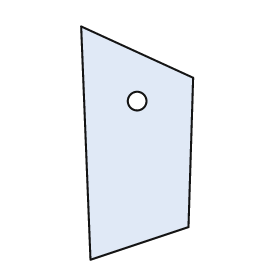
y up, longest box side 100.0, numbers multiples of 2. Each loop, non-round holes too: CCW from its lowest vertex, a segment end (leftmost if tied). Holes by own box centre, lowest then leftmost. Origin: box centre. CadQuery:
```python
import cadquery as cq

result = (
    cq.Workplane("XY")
    .moveTo(-20.0, -50.0)
    .lineTo(22.0, -36.0)
    .lineTo(24.0, 28.0)
    .lineTo(-24.0, 50.0)
    .close()
    .moveTo(0.0, 18.0)
    .circle(4.0)
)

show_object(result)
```